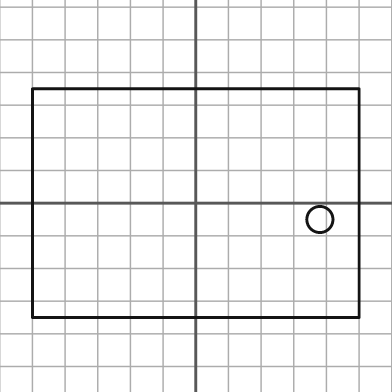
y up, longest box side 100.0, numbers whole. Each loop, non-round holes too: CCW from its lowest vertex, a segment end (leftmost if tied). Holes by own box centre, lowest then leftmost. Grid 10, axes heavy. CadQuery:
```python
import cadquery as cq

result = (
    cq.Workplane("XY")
    .moveTo(-50.0, -35.0)
    .lineTo(50.0, -35.0)
    .lineTo(50.0, 35.0)
    .lineTo(-50.0, 35.0)
    .close()
    .moveTo(38.0, -5.0)
    .circle(4.0)
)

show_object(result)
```